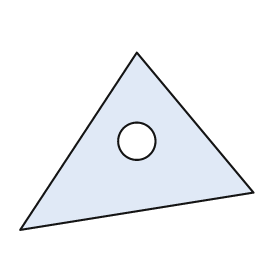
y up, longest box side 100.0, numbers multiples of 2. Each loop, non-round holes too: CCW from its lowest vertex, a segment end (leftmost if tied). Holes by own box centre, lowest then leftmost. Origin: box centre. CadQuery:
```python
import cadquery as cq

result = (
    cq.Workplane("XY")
    .moveTo(-50.0, -38.0)
    .lineTo(50.0, -22.0)
    .lineTo(0.0, 38.0)
    .close()
    .moveTo(0.0, 0.0)
    .circle(8.0)
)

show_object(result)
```